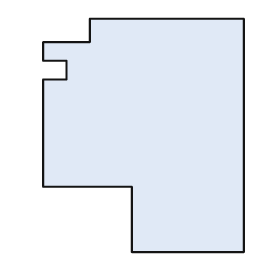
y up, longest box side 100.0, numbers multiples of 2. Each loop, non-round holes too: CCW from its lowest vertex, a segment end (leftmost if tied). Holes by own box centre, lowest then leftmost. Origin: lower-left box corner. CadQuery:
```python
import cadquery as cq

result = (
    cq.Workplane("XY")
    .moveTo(38.0, 0.0)
    .lineTo(86.0, 0.0)
    .lineTo(86.0, 100.0)
    .lineTo(20.0, 100.0)
    .lineTo(20.0, 90.0)
    .lineTo(0.0, 90.0)
    .lineTo(0.0, 82.0)
    .lineTo(10.0, 82.0)
    .lineTo(10.0, 74.0)
    .lineTo(0.0, 74.0)
    .lineTo(0.0, 28.0)
    .lineTo(38.0, 28.0)
    .close()
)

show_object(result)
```